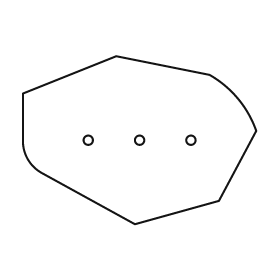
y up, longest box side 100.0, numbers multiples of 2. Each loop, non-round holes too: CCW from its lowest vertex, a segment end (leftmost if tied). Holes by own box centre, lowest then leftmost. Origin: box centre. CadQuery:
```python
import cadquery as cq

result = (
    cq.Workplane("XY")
    .moveTo(-2.0, -36.0)
    .lineTo(34.0, -26.0)
    .lineTo(50.0, 4.0)
    .threePointArc((42.0, 18.0), (30.0, 28.0))
    .lineTo(-10.0, 36.0)
    .lineTo(-50.0, 20.0)
    .lineTo(-50.0, 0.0)
    .threePointArc((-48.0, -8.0), (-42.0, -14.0))
    .close()
    .moveTo(-22.0, 0.0)
    .circle(2.0)
    .moveTo(0.0, 0.0)
    .circle(2.0)
    .moveTo(22.0, 0.0)
    .circle(2.0)
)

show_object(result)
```